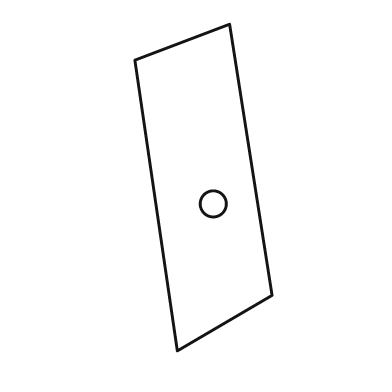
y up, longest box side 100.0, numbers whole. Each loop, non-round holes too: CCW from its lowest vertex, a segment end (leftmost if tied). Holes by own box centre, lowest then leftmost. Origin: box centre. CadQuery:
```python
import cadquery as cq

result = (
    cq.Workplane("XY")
    .moveTo(-8.0, -50.0)
    .lineTo(21.0, -33.0)
    .lineTo(8.0, 50.0)
    .lineTo(-21.0, 39.0)
    .close()
    .moveTo(3.0, -5.0)
    .circle(4.0)
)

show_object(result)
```